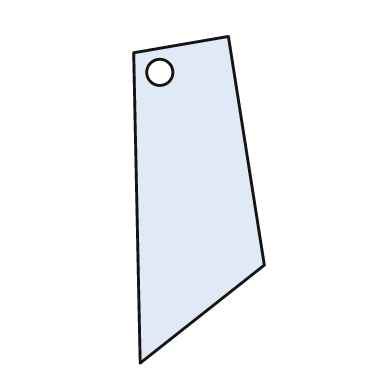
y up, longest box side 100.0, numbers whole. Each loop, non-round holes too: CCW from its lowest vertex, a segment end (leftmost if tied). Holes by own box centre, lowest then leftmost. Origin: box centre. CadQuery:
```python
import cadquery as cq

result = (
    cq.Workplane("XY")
    .moveTo(-18.0, -50.0)
    .lineTo(20.0, -20.0)
    .lineTo(9.0, 50.0)
    .lineTo(-20.0, 45.0)
    .close()
    .moveTo(-12.0, 39.0)
    .circle(4.0)
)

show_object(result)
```